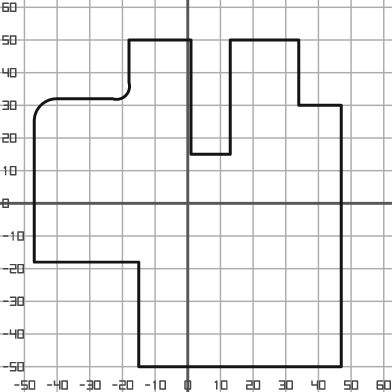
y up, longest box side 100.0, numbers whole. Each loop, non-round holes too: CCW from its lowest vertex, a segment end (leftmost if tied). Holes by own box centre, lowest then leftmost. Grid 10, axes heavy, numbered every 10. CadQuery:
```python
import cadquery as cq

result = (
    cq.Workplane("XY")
    .moveTo(-15.0, -50.0)
    .lineTo(47.0, -50.0)
    .lineTo(47.0, 30.0)
    .lineTo(34.0, 30.0)
    .lineTo(34.0, 50.0)
    .lineTo(13.0, 50.0)
    .lineTo(13.0, 15.0)
    .lineTo(1.0, 15.0)
    .lineTo(1.0, 50.0)
    .lineTo(-18.0, 50.0)
    .lineTo(-18.0, 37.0)
    .threePointArc((-19.0, 33.0), (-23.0, 32.0))
    .lineTo(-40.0, 32.0)
    .threePointArc((-45.0, 30.0), (-47.0, 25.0))
    .lineTo(-47.0, -18.0)
    .lineTo(-15.0, -18.0)
    .close()
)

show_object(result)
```